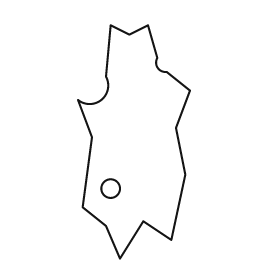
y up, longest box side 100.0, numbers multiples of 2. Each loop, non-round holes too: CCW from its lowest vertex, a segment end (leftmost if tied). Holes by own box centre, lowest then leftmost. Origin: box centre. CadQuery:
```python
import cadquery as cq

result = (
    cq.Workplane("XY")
    .moveTo(-6.0, -50.0)
    .lineTo(4.0, -34.0)
    .lineTo(16.0, -42.0)
    .lineTo(22.0, -14.0)
    .lineTo(18.0, 6.0)
    .lineTo(24.0, 22.0)
    .lineTo(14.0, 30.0)
    .threePointArc((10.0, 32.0), (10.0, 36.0))
    .lineTo(6.0, 50.0)
    .lineTo(-2.0, 46.0)
    .lineTo(-10.0, 50.0)
    .lineTo(-12.0, 28.0)
    .threePointArc((-14.0, 18.0), (-24.0, 18.0))
    .lineTo(-18.0, 2.0)
    .lineTo(-22.0, -28.0)
    .lineTo(-12.0, -36.0)
    .close()
    .moveTo(-10.0, -20.0)
    .circle(4.0)
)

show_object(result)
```